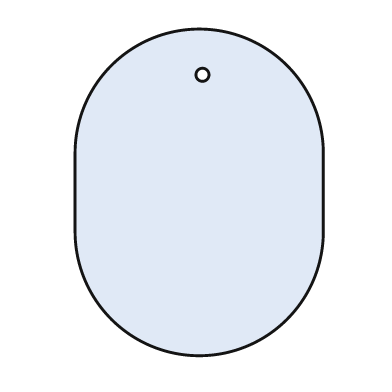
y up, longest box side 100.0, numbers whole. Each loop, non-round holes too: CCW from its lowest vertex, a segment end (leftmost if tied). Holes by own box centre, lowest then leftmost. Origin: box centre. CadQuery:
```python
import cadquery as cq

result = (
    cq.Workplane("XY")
    .moveTo(-38.0, -12.0)
    .threePointArc((0.0, -50.0), (38.0, -12.0))
    .lineTo(38.0, 12.0)
    .threePointArc((0.0, 50.0), (-38.0, 12.0))
    .close()
    .moveTo(1.0, 36.0)
    .circle(2.0)
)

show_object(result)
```